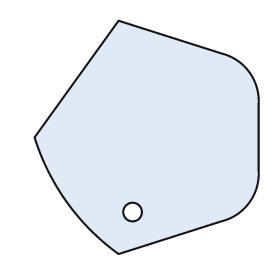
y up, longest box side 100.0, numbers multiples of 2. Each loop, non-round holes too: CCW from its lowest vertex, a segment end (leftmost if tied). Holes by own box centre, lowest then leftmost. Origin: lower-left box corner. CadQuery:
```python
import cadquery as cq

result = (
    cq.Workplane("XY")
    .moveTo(36.0, 0.0)
    .lineTo(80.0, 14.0)
    .threePointArc((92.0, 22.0), (96.0, 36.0))
    .lineTo(96.0, 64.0)
    .threePointArc((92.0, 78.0), (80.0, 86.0))
    .lineTo(36.0, 100.0)
    .lineTo(0.0, 50.0)
    .threePointArc((14.0, 22.0), (36.0, 0.0))
    .close()
    .moveTo(42.0, 18.0)
    .circle(4.0)
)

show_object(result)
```